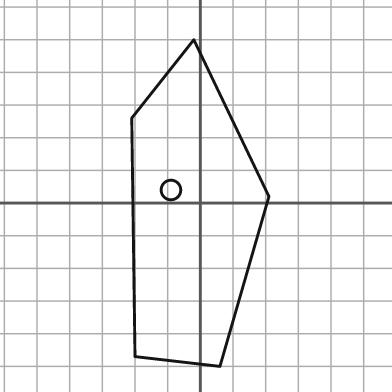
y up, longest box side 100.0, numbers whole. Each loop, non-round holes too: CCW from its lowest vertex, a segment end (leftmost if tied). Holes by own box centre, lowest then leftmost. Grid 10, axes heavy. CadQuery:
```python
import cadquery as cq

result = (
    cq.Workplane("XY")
    .moveTo(6.0, -50.0)
    .lineTo(21.0, 2.0)
    .lineTo(-2.0, 50.0)
    .lineTo(-21.0, 26.0)
    .lineTo(-20.0, -47.0)
    .close()
    .moveTo(-9.0, 4.0)
    .circle(3.0)
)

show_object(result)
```